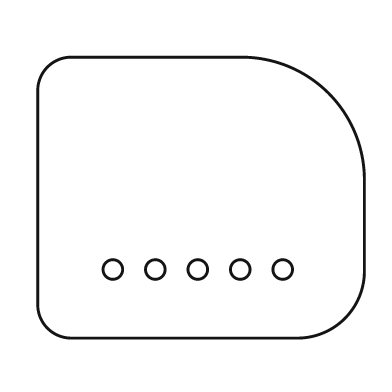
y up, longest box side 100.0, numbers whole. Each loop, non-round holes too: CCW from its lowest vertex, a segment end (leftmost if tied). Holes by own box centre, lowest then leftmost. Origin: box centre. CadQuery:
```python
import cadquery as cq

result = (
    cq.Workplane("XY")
    .moveTo(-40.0, -43.0)
    .lineTo(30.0, -43.0)
    .threePointArc((44.0, -37.0), (50.0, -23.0))
    .lineTo(50.0, 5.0)
    .threePointArc((39.0, 32.0), (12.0, 43.0))
    .lineTo(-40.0, 43.0)
    .threePointArc((-47.0, 40.0), (-50.0, 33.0))
    .lineTo(-50.0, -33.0)
    .threePointArc((-47.0, -40.0), (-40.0, -43.0))
    .close()
    .moveTo(-27.0, -22.0)
    .circle(3.0)
    .moveTo(-14.0, -22.0)
    .circle(3.0)
    .moveTo(-1.0, -22.0)
    .circle(3.0)
    .moveTo(12.0, -22.0)
    .circle(3.0)
    .moveTo(25.0, -22.0)
    .circle(3.0)
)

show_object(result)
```